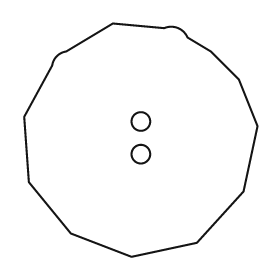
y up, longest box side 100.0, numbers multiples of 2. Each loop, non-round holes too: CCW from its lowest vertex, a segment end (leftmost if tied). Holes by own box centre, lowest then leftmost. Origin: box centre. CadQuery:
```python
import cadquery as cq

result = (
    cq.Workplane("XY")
    .moveTo(-4.0, -50.0)
    .lineTo(24.0, -44.0)
    .lineTo(44.0, -22.0)
    .lineTo(50.0, 6.0)
    .lineTo(42.0, 26.0)
    .lineTo(30.0, 38.0)
    .lineTo(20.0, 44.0)
    .threePointArc((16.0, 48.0), (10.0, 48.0))
    .lineTo(-12.0, 50.0)
    .lineTo(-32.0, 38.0)
    .threePointArc((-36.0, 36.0), (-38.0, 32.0))
    .lineTo(-50.0, 10.0)
    .lineTo(-48.0, -18.0)
    .lineTo(-30.0, -40.0)
    .close()
    .moveTo(0.0, -6.0)
    .circle(4.0)
    .moveTo(0.0, 8.0)
    .circle(4.0)
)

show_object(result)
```